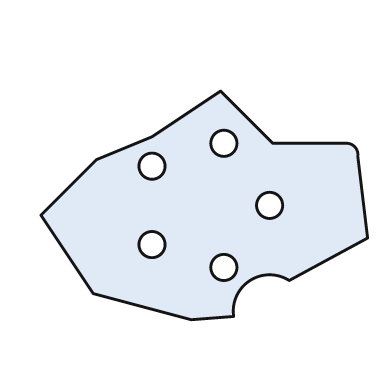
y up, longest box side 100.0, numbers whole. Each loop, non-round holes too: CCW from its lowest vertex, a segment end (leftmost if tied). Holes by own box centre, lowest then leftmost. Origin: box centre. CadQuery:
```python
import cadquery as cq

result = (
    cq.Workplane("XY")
    .moveTo(-4.0, -35.0)
    .lineTo(9.0, -34.0)
    .threePointArc((14.0, -23.0), (26.0, -23.0))
    .lineTo(50.0, -10.0)
    .lineTo(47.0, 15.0)
    .threePointArc((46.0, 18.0), (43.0, 19.0))
    .lineTo(21.0, 19.0)
    .lineTo(5.0, 35.0)
    .lineTo(-16.0, 21.0)
    .lineTo(-33.0, 14.0)
    .lineTo(-50.0, -3.0)
    .lineTo(-34.0, -27.0)
    .close()
    .moveTo(6.0, -19.0)
    .circle(4.0)
    .moveTo(-16.0, -12.0)
    .circle(4.0)
    .moveTo(20.0, 0.0)
    .circle(4.0)
    .moveTo(-16.0, 12.0)
    .circle(4.0)
    .moveTo(6.0, 19.0)
    .circle(4.0)
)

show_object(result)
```